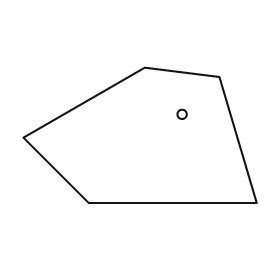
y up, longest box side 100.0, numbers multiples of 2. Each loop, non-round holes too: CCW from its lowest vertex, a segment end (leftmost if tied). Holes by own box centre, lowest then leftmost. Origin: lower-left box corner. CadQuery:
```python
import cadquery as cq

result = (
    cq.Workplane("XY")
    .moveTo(28.0, 0.0)
    .lineTo(100.0, 0.0)
    .lineTo(84.0, 54.0)
    .lineTo(52.0, 58.0)
    .lineTo(0.0, 28.0)
    .close()
    .moveTo(68.0, 38.0)
    .circle(2.0)
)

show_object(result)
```